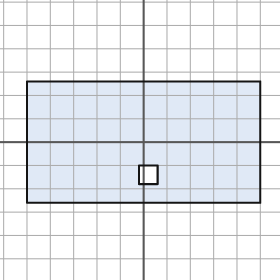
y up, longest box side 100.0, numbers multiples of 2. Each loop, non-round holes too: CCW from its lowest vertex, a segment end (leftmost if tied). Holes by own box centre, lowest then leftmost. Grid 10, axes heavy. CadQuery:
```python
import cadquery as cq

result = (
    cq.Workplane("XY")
    .moveTo(-50.0, -26.0)
    .lineTo(50.0, -26.0)
    .lineTo(50.0, 26.0)
    .lineTo(-50.0, 26.0)
    .close()
    .moveTo(-2.0, -18.0)
    .lineTo(6.0, -18.0)
    .lineTo(6.0, -10.0)
    .lineTo(-2.0, -10.0)
    .close()
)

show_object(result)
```